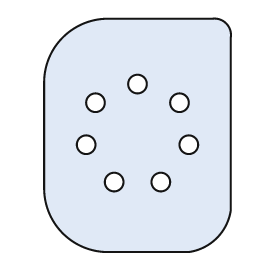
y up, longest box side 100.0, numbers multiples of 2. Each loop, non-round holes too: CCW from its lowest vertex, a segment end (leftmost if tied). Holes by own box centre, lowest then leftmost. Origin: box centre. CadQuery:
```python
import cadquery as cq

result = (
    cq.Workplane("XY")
    .moveTo(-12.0, -50.0)
    .lineTo(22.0, -50.0)
    .threePointArc((34.0, -44.0), (40.0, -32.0))
    .lineTo(40.0, 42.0)
    .threePointArc((38.0, 48.0), (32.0, 50.0))
    .lineTo(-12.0, 50.0)
    .threePointArc((-32.0, 42.0), (-40.0, 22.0))
    .lineTo(-40.0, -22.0)
    .threePointArc((-32.0, -42.0), (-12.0, -50.0))
    .close()
    .moveTo(-10.0, -20.0)
    .circle(4.0)
    .moveTo(10.0, -20.0)
    .circle(4.0)
    .moveTo(-22.0, -4.0)
    .circle(4.0)
    .moveTo(22.0, -4.0)
    .circle(4.0)
    .moveTo(-18.0, 14.0)
    .circle(4.0)
    .moveTo(18.0, 14.0)
    .circle(4.0)
    .moveTo(0.0, 22.0)
    .circle(4.0)
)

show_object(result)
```